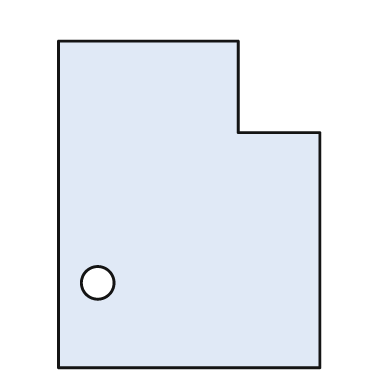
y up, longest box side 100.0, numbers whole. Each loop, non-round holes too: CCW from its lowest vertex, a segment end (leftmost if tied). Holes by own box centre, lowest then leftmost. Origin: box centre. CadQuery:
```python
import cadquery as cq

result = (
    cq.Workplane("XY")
    .moveTo(-40.0, -50.0)
    .lineTo(40.0, -50.0)
    .lineTo(40.0, 22.0)
    .lineTo(15.0, 22.0)
    .lineTo(15.0, 50.0)
    .lineTo(-40.0, 50.0)
    .close()
    .moveTo(-28.0, -24.0)
    .circle(5.0)
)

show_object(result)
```